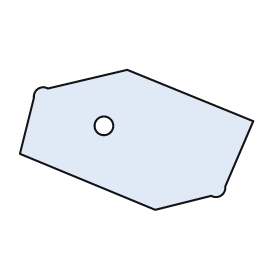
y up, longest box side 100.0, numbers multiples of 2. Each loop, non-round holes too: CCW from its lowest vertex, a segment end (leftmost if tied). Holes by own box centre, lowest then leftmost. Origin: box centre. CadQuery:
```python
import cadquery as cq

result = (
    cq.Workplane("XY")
    .moveTo(8.0, -30.0)
    .lineTo(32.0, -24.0)
    .threePointArc((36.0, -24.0), (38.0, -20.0))
    .lineTo(50.0, 8.0)
    .lineTo(-4.0, 30.0)
    .lineTo(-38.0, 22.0)
    .threePointArc((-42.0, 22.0), (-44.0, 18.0))
    .lineTo(-50.0, -6.0)
    .close()
    .moveTo(-14.0, 6.0)
    .circle(4.0)
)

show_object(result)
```